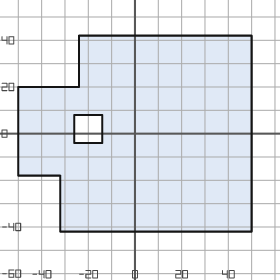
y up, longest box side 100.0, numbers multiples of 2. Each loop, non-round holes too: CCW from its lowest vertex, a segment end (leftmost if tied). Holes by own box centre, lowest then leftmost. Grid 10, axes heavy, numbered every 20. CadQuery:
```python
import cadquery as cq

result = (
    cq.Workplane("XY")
    .moveTo(-32.0, -42.0)
    .lineTo(50.0, -42.0)
    .lineTo(50.0, 42.0)
    .lineTo(-24.0, 42.0)
    .lineTo(-24.0, 20.0)
    .lineTo(-50.0, 20.0)
    .lineTo(-50.0, -18.0)
    .lineTo(-32.0, -18.0)
    .close()
    .moveTo(-26.0, -4.0)
    .lineTo(-14.0, -4.0)
    .lineTo(-14.0, 8.0)
    .lineTo(-26.0, 8.0)
    .close()
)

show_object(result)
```